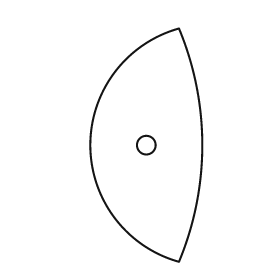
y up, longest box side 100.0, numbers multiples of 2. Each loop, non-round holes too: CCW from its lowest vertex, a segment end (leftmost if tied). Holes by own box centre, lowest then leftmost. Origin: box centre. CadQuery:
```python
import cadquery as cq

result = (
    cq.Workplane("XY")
    .moveTo(14.0, -50.0)
    .threePointArc((24.0, 0.0), (14.0, 50.0))
    .threePointArc((-24.0, 0.0), (14.0, -50.0))
    .close()
    .moveTo(0.0, 0.0)
    .circle(4.0)
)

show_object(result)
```